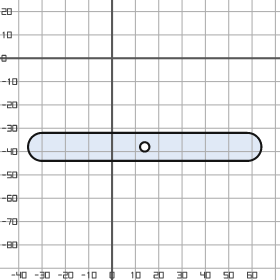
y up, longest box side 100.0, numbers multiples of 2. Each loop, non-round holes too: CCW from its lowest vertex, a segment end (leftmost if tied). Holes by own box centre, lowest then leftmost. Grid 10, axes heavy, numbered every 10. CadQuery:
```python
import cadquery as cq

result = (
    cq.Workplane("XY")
    .moveTo(-30.0, -44.0)
    .lineTo(58.0, -44.0)
    .threePointArc((64.0, -38.0), (58.0, -32.0))
    .lineTo(-30.0, -32.0)
    .threePointArc((-36.0, -38.0), (-30.0, -44.0))
    .close()
    .moveTo(14.0, -38.0)
    .circle(2.0)
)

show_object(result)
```